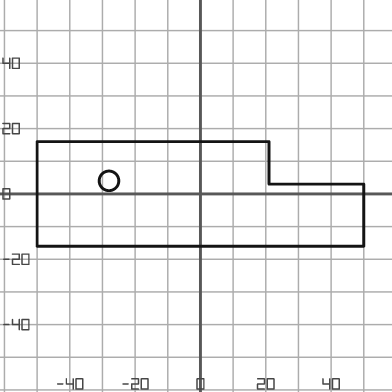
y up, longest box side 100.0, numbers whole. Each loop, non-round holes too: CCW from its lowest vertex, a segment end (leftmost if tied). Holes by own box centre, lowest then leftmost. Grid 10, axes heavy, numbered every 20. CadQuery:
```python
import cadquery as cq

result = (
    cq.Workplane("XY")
    .moveTo(-50.0, -16.0)
    .lineTo(50.0, -16.0)
    .lineTo(50.0, 3.0)
    .lineTo(21.0, 3.0)
    .lineTo(21.0, 16.0)
    .lineTo(-50.0, 16.0)
    .close()
    .moveTo(-28.0, 4.0)
    .circle(3.0)
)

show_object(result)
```